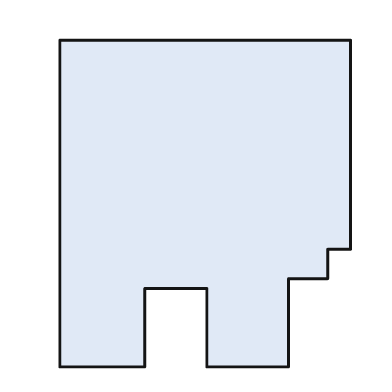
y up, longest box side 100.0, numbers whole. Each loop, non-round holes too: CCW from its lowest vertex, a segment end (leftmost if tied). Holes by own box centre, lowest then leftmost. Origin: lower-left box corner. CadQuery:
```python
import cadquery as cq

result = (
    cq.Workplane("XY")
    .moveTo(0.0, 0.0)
    .lineTo(26.0, 0.0)
    .lineTo(26.0, 24.0)
    .lineTo(45.0, 24.0)
    .lineTo(45.0, 0.0)
    .lineTo(70.0, 0.0)
    .lineTo(70.0, 27.0)
    .lineTo(82.0, 27.0)
    .lineTo(82.0, 36.0)
    .lineTo(89.0, 36.0)
    .lineTo(89.0, 100.0)
    .lineTo(0.0, 100.0)
    .close()
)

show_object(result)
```